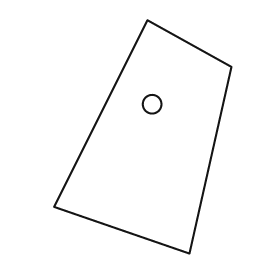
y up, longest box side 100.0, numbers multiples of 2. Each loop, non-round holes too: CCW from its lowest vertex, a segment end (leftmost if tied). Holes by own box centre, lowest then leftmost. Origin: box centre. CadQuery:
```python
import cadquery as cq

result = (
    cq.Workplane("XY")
    .moveTo(20.0, -50.0)
    .lineTo(38.0, 30.0)
    .lineTo(2.0, 50.0)
    .lineTo(-38.0, -30.0)
    .close()
    .moveTo(4.0, 14.0)
    .circle(4.0)
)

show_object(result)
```